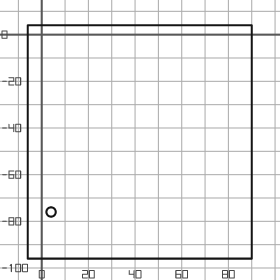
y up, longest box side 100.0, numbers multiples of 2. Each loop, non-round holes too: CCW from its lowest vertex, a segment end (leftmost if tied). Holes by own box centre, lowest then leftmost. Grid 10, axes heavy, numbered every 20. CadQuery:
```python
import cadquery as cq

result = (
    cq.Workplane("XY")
    .moveTo(-6.0, -96.0)
    .lineTo(90.0, -96.0)
    .lineTo(90.0, 4.0)
    .lineTo(-6.0, 4.0)
    .close()
    .moveTo(4.0, -76.0)
    .circle(2.0)
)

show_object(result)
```